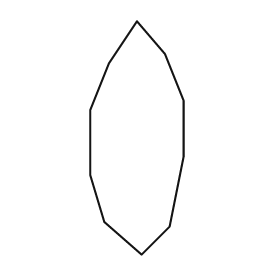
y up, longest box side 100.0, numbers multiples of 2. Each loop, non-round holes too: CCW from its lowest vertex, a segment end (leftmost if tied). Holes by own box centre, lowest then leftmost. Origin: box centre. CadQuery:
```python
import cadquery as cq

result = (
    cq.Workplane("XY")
    .moveTo(2.0, -50.0)
    .lineTo(14.0, -38.0)
    .lineTo(20.0, -8.0)
    .lineTo(20.0, 16.0)
    .lineTo(12.0, 36.0)
    .lineTo(0.0, 50.0)
    .lineTo(-12.0, 32.0)
    .lineTo(-20.0, 12.0)
    .lineTo(-20.0, -16.0)
    .lineTo(-14.0, -36.0)
    .close()
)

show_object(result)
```